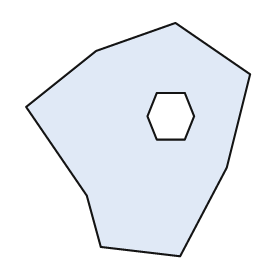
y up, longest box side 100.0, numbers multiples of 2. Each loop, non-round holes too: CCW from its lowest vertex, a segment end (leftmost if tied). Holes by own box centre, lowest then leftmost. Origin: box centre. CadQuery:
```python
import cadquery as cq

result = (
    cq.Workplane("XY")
    .moveTo(18.0, -50.0)
    .lineTo(38.0, -12.0)
    .lineTo(48.0, 28.0)
    .lineTo(16.0, 50.0)
    .lineTo(-18.0, 38.0)
    .lineTo(-48.0, 14.0)
    .lineTo(-22.0, -24.0)
    .lineTo(-16.0, -46.0)
    .close()
    .moveTo(8.0, 0.0)
    .lineTo(20.0, 0.0)
    .lineTo(24.0, 10.0)
    .lineTo(20.0, 20.0)
    .lineTo(8.0, 20.0)
    .lineTo(4.0, 10.0)
    .close()
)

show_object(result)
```